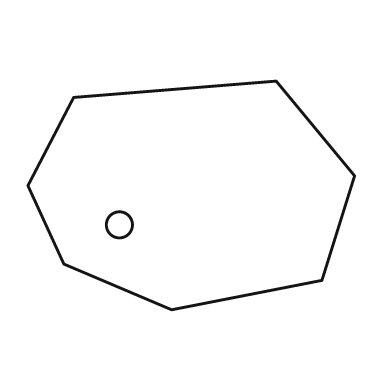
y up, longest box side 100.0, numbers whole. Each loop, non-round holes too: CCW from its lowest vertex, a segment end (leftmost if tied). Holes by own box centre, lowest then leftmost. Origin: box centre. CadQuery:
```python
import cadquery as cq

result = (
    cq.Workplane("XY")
    .moveTo(-6.0, -35.0)
    .lineTo(40.0, -26.0)
    .lineTo(50.0, 6.0)
    .lineTo(26.0, 35.0)
    .lineTo(-36.0, 30.0)
    .lineTo(-50.0, 3.0)
    .lineTo(-39.0, -21.0)
    .close()
    .moveTo(-22.0, -9.0)
    .circle(4.0)
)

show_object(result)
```